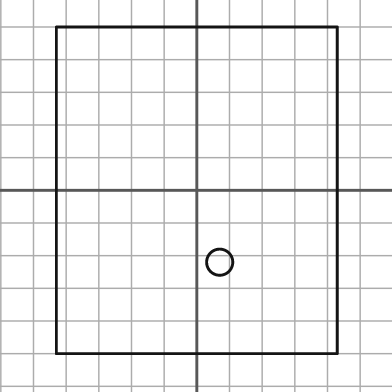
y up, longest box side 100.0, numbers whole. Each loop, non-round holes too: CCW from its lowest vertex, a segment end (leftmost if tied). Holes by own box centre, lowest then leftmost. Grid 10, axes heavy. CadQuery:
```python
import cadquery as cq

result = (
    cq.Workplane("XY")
    .moveTo(-43.0, -50.0)
    .lineTo(43.0, -50.0)
    .lineTo(43.0, 50.0)
    .lineTo(-43.0, 50.0)
    .close()
    .moveTo(7.0, -22.0)
    .circle(4.0)
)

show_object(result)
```